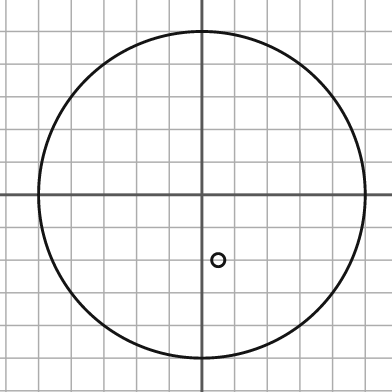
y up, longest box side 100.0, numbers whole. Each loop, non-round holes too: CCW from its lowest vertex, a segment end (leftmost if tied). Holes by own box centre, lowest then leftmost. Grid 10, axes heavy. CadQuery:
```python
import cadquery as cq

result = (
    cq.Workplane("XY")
    .moveTo(0.0, 0.0)
    .circle(50.0)
    .moveTo(5.0, -20.0)
    .circle(2.0)
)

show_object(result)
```